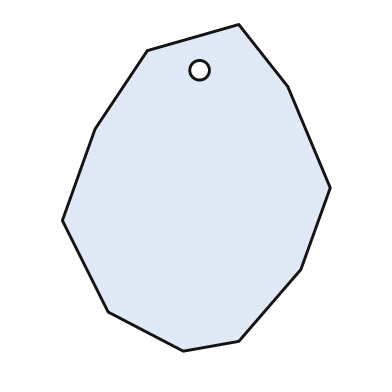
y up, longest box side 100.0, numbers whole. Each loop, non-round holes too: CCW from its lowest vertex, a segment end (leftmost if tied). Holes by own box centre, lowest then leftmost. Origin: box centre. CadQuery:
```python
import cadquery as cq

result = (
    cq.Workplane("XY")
    .moveTo(-4.0, -50.0)
    .lineTo(13.0, -47.0)
    .lineTo(32.0, -25.0)
    .lineTo(41.0, 0.0)
    .lineTo(28.0, 31.0)
    .lineTo(13.0, 50.0)
    .lineTo(-15.0, 42.0)
    .lineTo(-31.0, 18.0)
    .lineTo(-41.0, -10.0)
    .lineTo(-27.0, -38.0)
    .close()
    .moveTo(1.0, 36.0)
    .circle(3.0)
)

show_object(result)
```